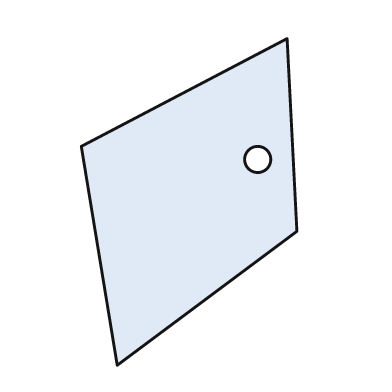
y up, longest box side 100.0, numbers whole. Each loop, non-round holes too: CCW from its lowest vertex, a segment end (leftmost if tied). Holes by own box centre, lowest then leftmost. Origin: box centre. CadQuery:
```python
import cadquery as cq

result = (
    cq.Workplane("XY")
    .moveTo(-22.0, -50.0)
    .lineTo(33.0, -9.0)
    .lineTo(30.0, 50.0)
    .lineTo(-33.0, 17.0)
    .close()
    .moveTo(21.0, 13.0)
    .circle(4.0)
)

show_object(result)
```